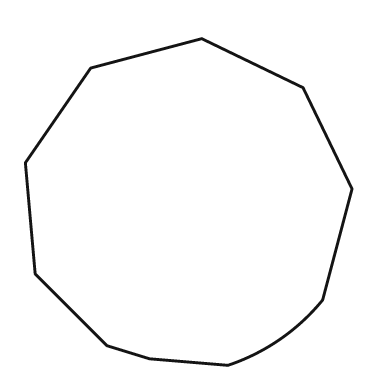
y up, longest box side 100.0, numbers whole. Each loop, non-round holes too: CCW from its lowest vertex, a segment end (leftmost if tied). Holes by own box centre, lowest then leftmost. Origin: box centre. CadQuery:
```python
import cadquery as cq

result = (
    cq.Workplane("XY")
    .moveTo(12.0, -50.0)
    .threePointArc((28.0, -42.0), (41.0, -30.0))
    .lineTo(50.0, 4.0)
    .lineTo(35.0, 35.0)
    .lineTo(4.0, 50.0)
    .lineTo(-30.0, 41.0)
    .lineTo(-50.0, 12.0)
    .lineTo(-47.0, -22.0)
    .lineTo(-25.0, -44.0)
    .lineTo(-12.0, -48.0)
    .close()
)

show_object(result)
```